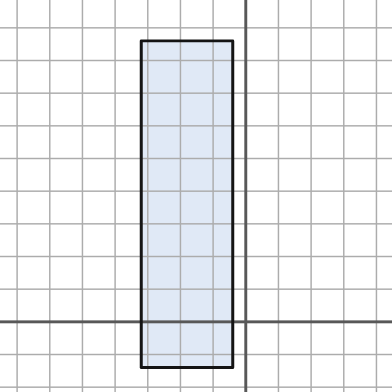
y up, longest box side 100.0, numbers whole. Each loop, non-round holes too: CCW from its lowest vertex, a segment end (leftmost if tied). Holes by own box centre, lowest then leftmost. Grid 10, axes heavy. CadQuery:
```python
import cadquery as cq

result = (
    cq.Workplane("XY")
    .moveTo(-32.0, -14.0)
    .lineTo(-4.0, -14.0)
    .lineTo(-4.0, 86.0)
    .lineTo(-32.0, 86.0)
    .close()
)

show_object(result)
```